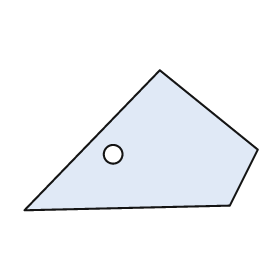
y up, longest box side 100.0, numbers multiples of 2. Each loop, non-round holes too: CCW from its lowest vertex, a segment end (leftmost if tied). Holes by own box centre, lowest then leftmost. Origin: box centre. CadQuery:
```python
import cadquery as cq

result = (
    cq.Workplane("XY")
    .moveTo(-50.0, -30.0)
    .lineTo(38.0, -28.0)
    .lineTo(50.0, -4.0)
    .lineTo(8.0, 30.0)
    .close()
    .moveTo(-12.0, -6.0)
    .circle(4.0)
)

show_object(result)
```